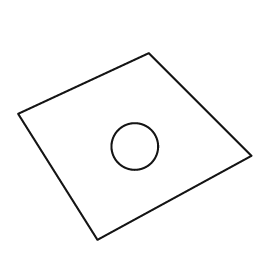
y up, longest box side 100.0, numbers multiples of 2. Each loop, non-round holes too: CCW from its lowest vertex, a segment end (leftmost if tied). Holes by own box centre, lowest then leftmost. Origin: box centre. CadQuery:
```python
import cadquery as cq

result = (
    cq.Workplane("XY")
    .moveTo(-16.0, -40.0)
    .lineTo(50.0, -4.0)
    .lineTo(6.0, 40.0)
    .lineTo(-50.0, 14.0)
    .close()
    .moveTo(0.0, 0.0)
    .circle(10.0)
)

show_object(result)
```